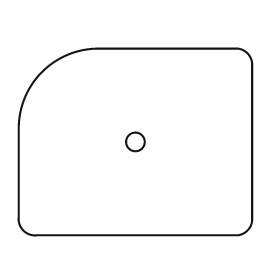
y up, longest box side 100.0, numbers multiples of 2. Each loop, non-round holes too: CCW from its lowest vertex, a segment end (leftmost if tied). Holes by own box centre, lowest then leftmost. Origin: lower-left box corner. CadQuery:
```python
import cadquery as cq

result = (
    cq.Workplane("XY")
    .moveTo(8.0, 0.0)
    .lineTo(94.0, 0.0)
    .threePointArc((98.0, 2.0), (100.0, 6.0))
    .lineTo(100.0, 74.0)
    .threePointArc((98.0, 78.0), (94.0, 80.0))
    .lineTo(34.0, 80.0)
    .threePointArc((10.0, 70.0), (0.0, 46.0))
    .lineTo(0.0, 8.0)
    .threePointArc((2.0, 2.0), (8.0, 0.0))
    .close()
    .moveTo(50.0, 40.0)
    .circle(4.0)
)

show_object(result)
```